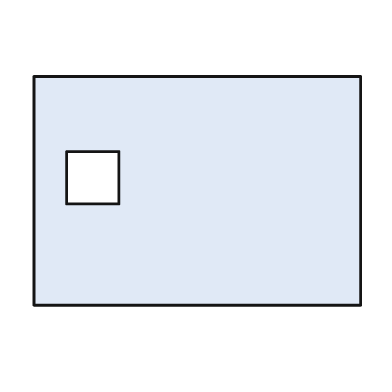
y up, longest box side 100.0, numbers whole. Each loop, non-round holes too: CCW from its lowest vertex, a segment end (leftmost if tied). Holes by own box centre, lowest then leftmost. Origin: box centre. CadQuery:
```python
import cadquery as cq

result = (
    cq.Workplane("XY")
    .moveTo(-50.0, -35.0)
    .lineTo(50.0, -35.0)
    .lineTo(50.0, 35.0)
    .lineTo(-50.0, 35.0)
    .close()
    .moveTo(-40.0, -4.0)
    .lineTo(-24.0, -4.0)
    .lineTo(-24.0, 12.0)
    .lineTo(-40.0, 12.0)
    .close()
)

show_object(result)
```